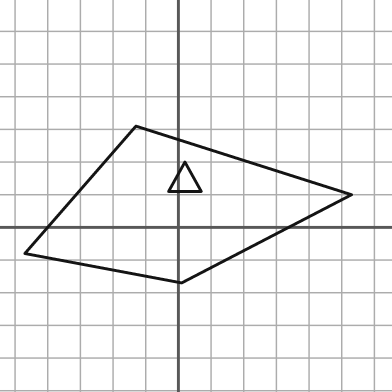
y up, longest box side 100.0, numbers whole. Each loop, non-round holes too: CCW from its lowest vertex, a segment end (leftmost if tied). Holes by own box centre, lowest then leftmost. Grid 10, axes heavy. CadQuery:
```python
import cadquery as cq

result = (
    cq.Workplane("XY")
    .moveTo(1.0, -17.0)
    .lineTo(53.0, 10.0)
    .lineTo(-13.0, 31.0)
    .lineTo(-47.0, -8.0)
    .close()
    .moveTo(-3.0, 11.0)
    .lineTo(7.0, 11.0)
    .lineTo(2.0, 20.0)
    .close()
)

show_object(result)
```